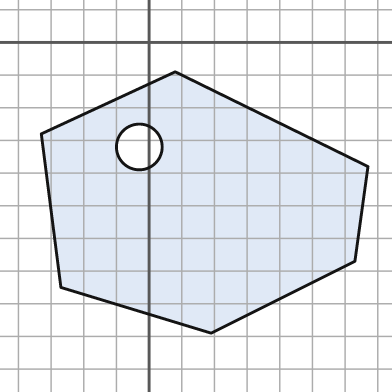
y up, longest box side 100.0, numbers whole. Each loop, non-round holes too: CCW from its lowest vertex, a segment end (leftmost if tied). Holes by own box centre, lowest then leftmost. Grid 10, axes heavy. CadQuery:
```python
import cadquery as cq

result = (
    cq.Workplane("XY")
    .moveTo(19.0, -89.0)
    .lineTo(63.0, -67.0)
    .lineTo(67.0, -38.0)
    .lineTo(8.0, -9.0)
    .lineTo(-33.0, -28.0)
    .lineTo(-27.0, -75.0)
    .close()
    .moveTo(-3.0, -32.0)
    .circle(7.0)
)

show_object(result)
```